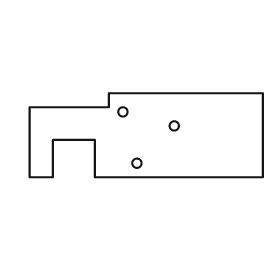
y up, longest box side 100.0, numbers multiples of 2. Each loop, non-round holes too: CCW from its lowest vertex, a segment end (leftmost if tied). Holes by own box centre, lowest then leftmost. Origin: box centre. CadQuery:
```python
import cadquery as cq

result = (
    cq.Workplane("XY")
    .moveTo(-50.0, -18.0)
    .lineTo(-40.0, -18.0)
    .lineTo(-40.0, -2.0)
    .lineTo(-22.0, -2.0)
    .lineTo(-22.0, -18.0)
    .lineTo(50.0, -18.0)
    .lineTo(50.0, 18.0)
    .lineTo(-16.0, 18.0)
    .lineTo(-16.0, 12.0)
    .lineTo(-50.0, 12.0)
    .close()
    .moveTo(-4.0, -12.0)
    .circle(2.0)
    .moveTo(12.0, 4.0)
    .circle(2.0)
    .moveTo(-10.0, 10.0)
    .circle(2.0)
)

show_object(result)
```